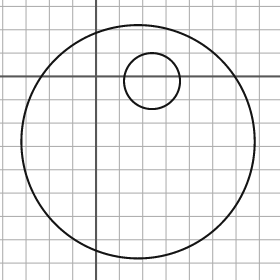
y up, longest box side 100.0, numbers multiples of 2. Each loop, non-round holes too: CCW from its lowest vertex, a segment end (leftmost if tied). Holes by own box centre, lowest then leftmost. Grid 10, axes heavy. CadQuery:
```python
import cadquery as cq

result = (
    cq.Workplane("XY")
    .moveTo(18.0, -28.0)
    .circle(50.0)
    .moveTo(24.0, -2.0)
    .circle(12.0)
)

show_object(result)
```